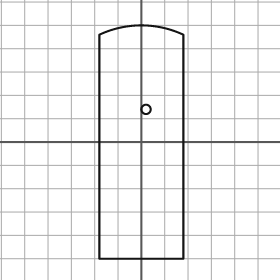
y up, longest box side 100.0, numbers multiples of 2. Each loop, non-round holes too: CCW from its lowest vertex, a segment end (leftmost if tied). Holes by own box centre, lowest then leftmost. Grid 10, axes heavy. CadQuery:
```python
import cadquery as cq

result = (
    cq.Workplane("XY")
    .moveTo(-18.0, -50.0)
    .lineTo(18.0, -50.0)
    .lineTo(18.0, 46.0)
    .threePointArc((0.0, 50.0), (-18.0, 46.0))
    .close()
    .moveTo(2.0, 14.0)
    .circle(2.0)
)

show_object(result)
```